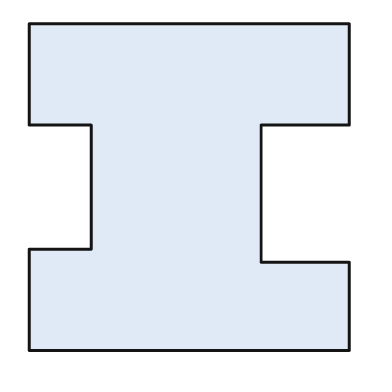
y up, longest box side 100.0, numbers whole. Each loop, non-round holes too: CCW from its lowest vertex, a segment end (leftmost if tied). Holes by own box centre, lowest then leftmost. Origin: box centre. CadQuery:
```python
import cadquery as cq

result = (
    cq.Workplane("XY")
    .moveTo(-49.0, -50.0)
    .lineTo(49.0, -50.0)
    .lineTo(49.0, -23.0)
    .lineTo(22.0, -23.0)
    .lineTo(22.0, 19.0)
    .lineTo(49.0, 19.0)
    .lineTo(49.0, 50.0)
    .lineTo(-49.0, 50.0)
    .lineTo(-49.0, 19.0)
    .lineTo(-30.0, 19.0)
    .lineTo(-30.0, -19.0)
    .lineTo(-49.0, -19.0)
    .close()
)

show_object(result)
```